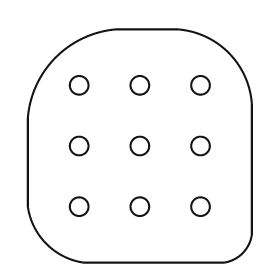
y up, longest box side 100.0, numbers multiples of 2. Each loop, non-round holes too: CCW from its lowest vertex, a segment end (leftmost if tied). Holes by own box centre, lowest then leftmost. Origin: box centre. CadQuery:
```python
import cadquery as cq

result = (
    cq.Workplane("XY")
    .moveTo(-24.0, -50.0)
    .lineTo(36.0, -50.0)
    .threePointArc((44.0, -46.0), (48.0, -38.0))
    .lineTo(48.0, 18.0)
    .threePointArc((38.0, 40.0), (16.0, 50.0))
    .lineTo(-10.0, 50.0)
    .threePointArc((-36.0, 38.0), (-48.0, 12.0))
    .lineTo(-48.0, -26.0)
    .threePointArc((-40.0, -42.0), (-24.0, -50.0))
    .close()
    .moveTo(-26.0, -26.0)
    .circle(4.0)
    .moveTo(0.0, -26.0)
    .circle(4.0)
    .moveTo(26.0, -26.0)
    .circle(4.0)
    .moveTo(-26.0, 0.0)
    .circle(4.0)
    .moveTo(0.0, 0.0)
    .circle(4.0)
    .moveTo(26.0, 0.0)
    .circle(4.0)
    .moveTo(-26.0, 26.0)
    .circle(4.0)
    .moveTo(0.0, 26.0)
    .circle(4.0)
    .moveTo(26.0, 26.0)
    .circle(4.0)
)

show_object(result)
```